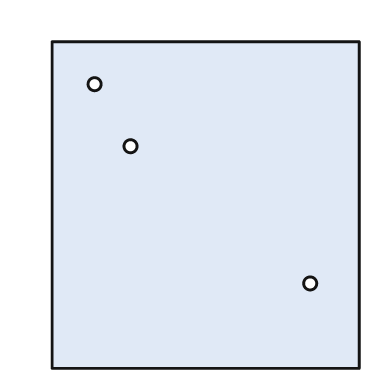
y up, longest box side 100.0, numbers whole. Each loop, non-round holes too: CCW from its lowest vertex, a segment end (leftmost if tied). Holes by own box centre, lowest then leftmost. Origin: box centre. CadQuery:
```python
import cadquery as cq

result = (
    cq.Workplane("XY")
    .moveTo(-47.0, -50.0)
    .lineTo(47.0, -50.0)
    .lineTo(47.0, 50.0)
    .lineTo(-47.0, 50.0)
    .close()
    .moveTo(32.0, -24.0)
    .circle(2.0)
    .moveTo(-23.0, 18.0)
    .circle(2.0)
    .moveTo(-34.0, 37.0)
    .circle(2.0)
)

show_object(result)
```